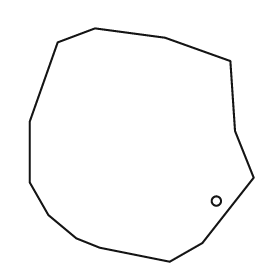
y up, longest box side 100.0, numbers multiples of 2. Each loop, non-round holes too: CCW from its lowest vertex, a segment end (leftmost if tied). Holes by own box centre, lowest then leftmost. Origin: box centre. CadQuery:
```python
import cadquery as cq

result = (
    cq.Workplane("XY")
    .moveTo(12.0, -50.0)
    .lineTo(26.0, -42.0)
    .lineTo(48.0, -14.0)
    .lineTo(40.0, 6.0)
    .lineTo(38.0, 36.0)
    .lineTo(10.0, 46.0)
    .lineTo(-20.0, 50.0)
    .lineTo(-36.0, 44.0)
    .lineTo(-48.0, 10.0)
    .lineTo(-48.0, -16.0)
    .lineTo(-40.0, -30.0)
    .lineTo(-28.0, -40.0)
    .lineTo(-18.0, -44.0)
    .close()
    .moveTo(32.0, -24.0)
    .circle(2.0)
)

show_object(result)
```